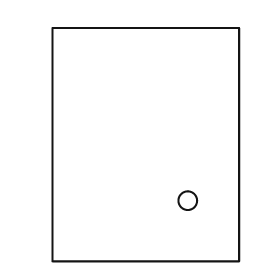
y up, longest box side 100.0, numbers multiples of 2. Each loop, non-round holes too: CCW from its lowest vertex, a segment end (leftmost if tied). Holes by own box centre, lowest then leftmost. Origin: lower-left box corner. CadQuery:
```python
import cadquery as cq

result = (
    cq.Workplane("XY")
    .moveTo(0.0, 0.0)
    .lineTo(80.0, 0.0)
    .lineTo(80.0, 100.0)
    .lineTo(0.0, 100.0)
    .close()
    .moveTo(58.0, 26.0)
    .circle(4.0)
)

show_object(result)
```